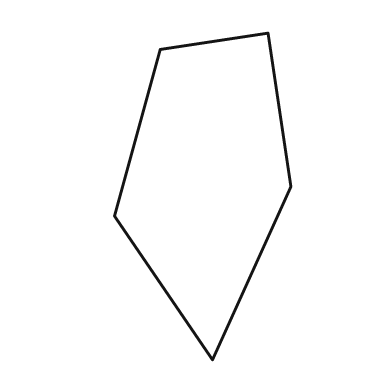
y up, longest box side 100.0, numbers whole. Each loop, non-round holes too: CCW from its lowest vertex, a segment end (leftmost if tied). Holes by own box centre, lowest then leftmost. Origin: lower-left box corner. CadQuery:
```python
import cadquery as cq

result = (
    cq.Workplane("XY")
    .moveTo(30.0, 0.0)
    .lineTo(54.0, 53.0)
    .lineTo(47.0, 100.0)
    .lineTo(14.0, 95.0)
    .lineTo(0.0, 44.0)
    .close()
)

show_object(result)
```